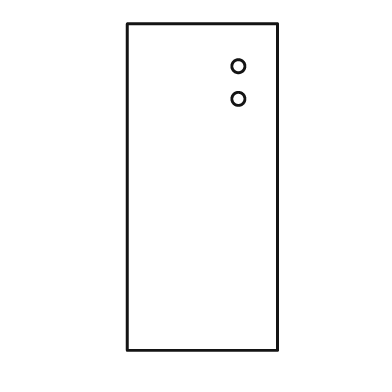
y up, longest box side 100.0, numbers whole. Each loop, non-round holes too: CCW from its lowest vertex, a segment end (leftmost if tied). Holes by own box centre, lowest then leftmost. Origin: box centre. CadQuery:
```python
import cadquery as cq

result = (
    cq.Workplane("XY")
    .moveTo(-23.0, -50.0)
    .lineTo(23.0, -50.0)
    .lineTo(23.0, 50.0)
    .lineTo(-23.0, 50.0)
    .close()
    .moveTo(11.0, 27.0)
    .circle(2.0)
    .moveTo(11.0, 37.0)
    .circle(2.0)
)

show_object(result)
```